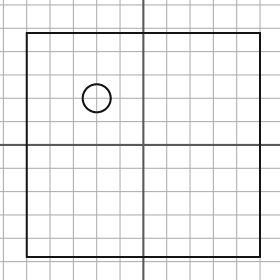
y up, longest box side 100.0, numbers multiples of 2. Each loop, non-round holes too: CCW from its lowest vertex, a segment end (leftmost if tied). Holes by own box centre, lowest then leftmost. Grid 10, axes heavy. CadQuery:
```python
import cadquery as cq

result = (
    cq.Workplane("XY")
    .moveTo(-50.0, -48.0)
    .lineTo(50.0, -48.0)
    .lineTo(50.0, 48.0)
    .lineTo(-50.0, 48.0)
    .close()
    .moveTo(-20.0, 20.0)
    .circle(6.0)
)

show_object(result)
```